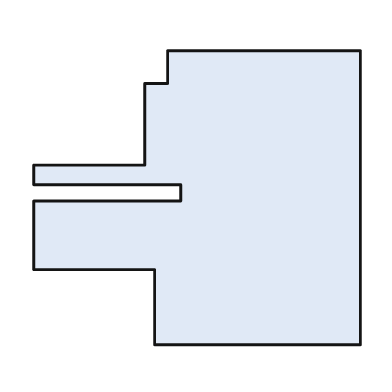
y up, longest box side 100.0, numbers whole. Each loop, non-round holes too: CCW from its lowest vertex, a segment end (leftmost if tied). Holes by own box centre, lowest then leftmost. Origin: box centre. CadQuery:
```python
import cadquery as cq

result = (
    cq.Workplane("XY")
    .moveTo(-13.0, -45.0)
    .lineTo(50.0, -45.0)
    .lineTo(50.0, 45.0)
    .lineTo(-9.0, 45.0)
    .lineTo(-9.0, 35.0)
    .lineTo(-16.0, 35.0)
    .lineTo(-16.0, 10.0)
    .lineTo(-50.0, 10.0)
    .lineTo(-50.0, 4.0)
    .lineTo(-5.0, 4.0)
    .lineTo(-5.0, -1.0)
    .lineTo(-50.0, -1.0)
    .lineTo(-50.0, -22.0)
    .lineTo(-13.0, -22.0)
    .close()
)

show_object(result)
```